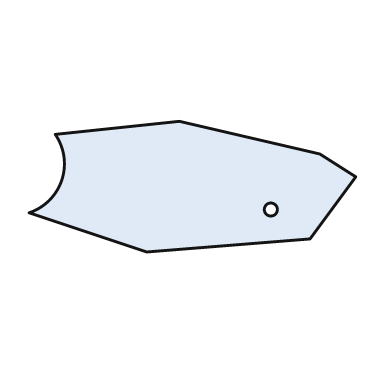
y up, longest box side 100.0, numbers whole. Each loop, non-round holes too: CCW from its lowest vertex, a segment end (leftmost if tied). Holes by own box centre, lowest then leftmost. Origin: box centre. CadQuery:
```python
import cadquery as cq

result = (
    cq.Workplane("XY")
    .moveTo(-14.0, -20.0)
    .lineTo(36.0, -16.0)
    .lineTo(50.0, 3.0)
    .lineTo(39.0, 10.0)
    .lineTo(-4.0, 20.0)
    .lineTo(-42.0, 16.0)
    .threePointArc((-40.0, 2.0), (-50.0, -8.0))
    .close()
    .moveTo(24.0, -7.0)
    .circle(2.0)
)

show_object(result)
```